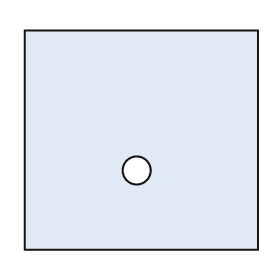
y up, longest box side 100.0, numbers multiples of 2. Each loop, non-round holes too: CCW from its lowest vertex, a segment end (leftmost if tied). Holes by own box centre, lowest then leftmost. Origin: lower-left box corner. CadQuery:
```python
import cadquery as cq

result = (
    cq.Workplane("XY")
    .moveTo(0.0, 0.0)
    .lineTo(100.0, 0.0)
    .lineTo(100.0, 94.0)
    .lineTo(0.0, 94.0)
    .close()
    .moveTo(48.0, 34.0)
    .circle(6.0)
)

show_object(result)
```